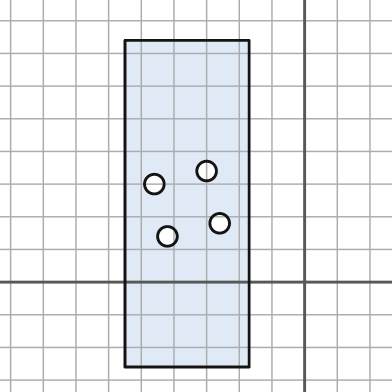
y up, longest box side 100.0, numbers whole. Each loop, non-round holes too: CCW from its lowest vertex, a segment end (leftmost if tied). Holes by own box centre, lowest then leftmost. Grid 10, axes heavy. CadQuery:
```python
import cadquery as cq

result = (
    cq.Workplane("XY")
    .moveTo(-55.0, -26.0)
    .lineTo(-17.0, -26.0)
    .lineTo(-17.0, 74.0)
    .lineTo(-55.0, 74.0)
    .close()
    .moveTo(-42.0, 14.0)
    .circle(3.0)
    .moveTo(-26.0, 18.0)
    .circle(3.0)
    .moveTo(-46.0, 30.0)
    .circle(3.0)
    .moveTo(-30.0, 34.0)
    .circle(3.0)
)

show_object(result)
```